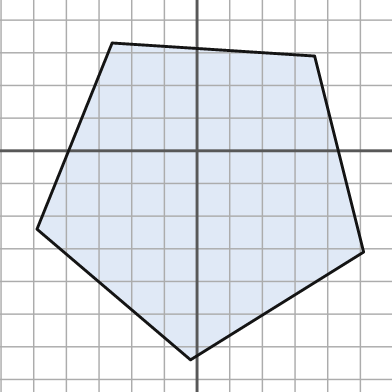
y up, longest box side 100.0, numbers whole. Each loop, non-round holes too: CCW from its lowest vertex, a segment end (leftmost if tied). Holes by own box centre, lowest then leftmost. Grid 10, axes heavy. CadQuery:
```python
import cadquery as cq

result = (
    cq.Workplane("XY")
    .moveTo(-2.0, -64.0)
    .lineTo(51.0, -31.0)
    .lineTo(36.0, 29.0)
    .lineTo(-26.0, 33.0)
    .lineTo(-49.0, -24.0)
    .close()
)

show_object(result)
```